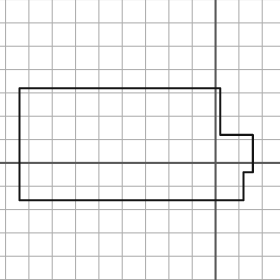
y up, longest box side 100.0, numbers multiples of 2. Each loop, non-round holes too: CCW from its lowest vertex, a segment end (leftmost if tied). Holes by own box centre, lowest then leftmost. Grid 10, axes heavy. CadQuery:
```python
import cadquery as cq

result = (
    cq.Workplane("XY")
    .moveTo(-84.0, -16.0)
    .lineTo(12.0, -16.0)
    .lineTo(12.0, -4.0)
    .lineTo(16.0, -4.0)
    .lineTo(16.0, 12.0)
    .lineTo(2.0, 12.0)
    .lineTo(2.0, 32.0)
    .lineTo(-84.0, 32.0)
    .close()
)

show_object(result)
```